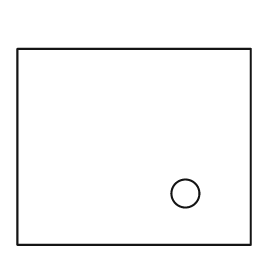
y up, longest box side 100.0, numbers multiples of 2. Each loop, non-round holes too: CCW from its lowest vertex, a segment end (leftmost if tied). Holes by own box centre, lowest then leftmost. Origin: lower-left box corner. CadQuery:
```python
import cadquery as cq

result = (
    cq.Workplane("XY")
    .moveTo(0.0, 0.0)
    .lineTo(100.0, 0.0)
    .lineTo(100.0, 84.0)
    .lineTo(0.0, 84.0)
    .close()
    .moveTo(72.0, 22.0)
    .circle(6.0)
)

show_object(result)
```